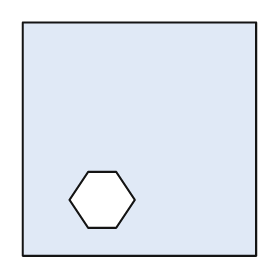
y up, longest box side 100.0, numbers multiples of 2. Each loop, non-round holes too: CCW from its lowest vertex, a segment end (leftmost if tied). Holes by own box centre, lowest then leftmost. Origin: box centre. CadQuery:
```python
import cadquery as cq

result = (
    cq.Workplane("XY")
    .moveTo(-50.0, -50.0)
    .lineTo(50.0, -50.0)
    .lineTo(50.0, 50.0)
    .lineTo(-50.0, 50.0)
    .close()
    .moveTo(-22.0, -38.0)
    .lineTo(-10.0, -38.0)
    .lineTo(-2.0, -26.0)
    .lineTo(-10.0, -14.0)
    .lineTo(-22.0, -14.0)
    .lineTo(-30.0, -26.0)
    .close()
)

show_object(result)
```